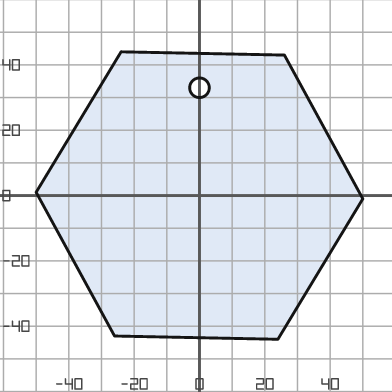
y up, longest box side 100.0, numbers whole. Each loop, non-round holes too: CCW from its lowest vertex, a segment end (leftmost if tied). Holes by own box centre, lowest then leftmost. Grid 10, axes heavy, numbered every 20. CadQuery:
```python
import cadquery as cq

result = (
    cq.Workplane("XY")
    .moveTo(24.0, -44.0)
    .lineTo(50.0, -1.0)
    .lineTo(26.0, 43.0)
    .lineTo(-24.0, 44.0)
    .lineTo(-50.0, 1.0)
    .lineTo(-26.0, -43.0)
    .close()
    .moveTo(0.0, 33.0)
    .circle(3.0)
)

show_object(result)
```